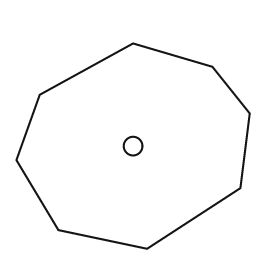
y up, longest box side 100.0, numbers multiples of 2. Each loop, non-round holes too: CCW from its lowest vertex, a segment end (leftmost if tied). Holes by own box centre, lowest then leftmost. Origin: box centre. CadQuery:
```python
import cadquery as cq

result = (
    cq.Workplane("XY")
    .moveTo(6.0, -44.0)
    .lineTo(46.0, -18.0)
    .lineTo(50.0, 14.0)
    .lineTo(34.0, 34.0)
    .lineTo(0.0, 44.0)
    .lineTo(-40.0, 22.0)
    .lineTo(-50.0, -6.0)
    .lineTo(-32.0, -36.0)
    .close()
    .moveTo(0.0, 0.0)
    .circle(4.0)
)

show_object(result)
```